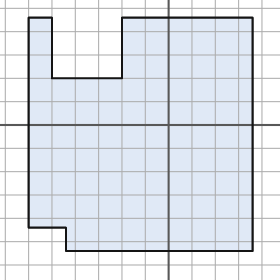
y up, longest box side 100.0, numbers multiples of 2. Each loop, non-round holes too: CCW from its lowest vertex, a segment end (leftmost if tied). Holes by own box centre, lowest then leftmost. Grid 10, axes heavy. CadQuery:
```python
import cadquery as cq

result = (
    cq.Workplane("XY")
    .moveTo(-44.0, -54.0)
    .lineTo(36.0, -54.0)
    .lineTo(36.0, 46.0)
    .lineTo(-20.0, 46.0)
    .lineTo(-20.0, 20.0)
    .lineTo(-50.0, 20.0)
    .lineTo(-50.0, 46.0)
    .lineTo(-60.0, 46.0)
    .lineTo(-60.0, -44.0)
    .lineTo(-44.0, -44.0)
    .close()
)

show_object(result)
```